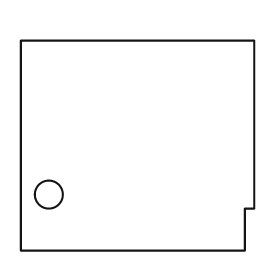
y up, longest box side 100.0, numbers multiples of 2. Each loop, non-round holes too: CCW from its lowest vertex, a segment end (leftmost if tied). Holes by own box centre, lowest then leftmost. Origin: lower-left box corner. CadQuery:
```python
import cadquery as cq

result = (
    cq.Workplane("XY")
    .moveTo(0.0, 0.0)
    .lineTo(96.0, 0.0)
    .lineTo(96.0, 18.0)
    .lineTo(100.0, 18.0)
    .lineTo(100.0, 90.0)
    .lineTo(0.0, 90.0)
    .close()
    .moveTo(12.0, 24.0)
    .circle(6.0)
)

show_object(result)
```